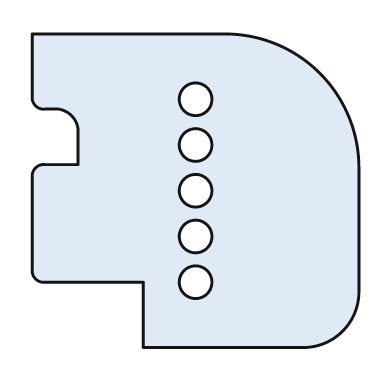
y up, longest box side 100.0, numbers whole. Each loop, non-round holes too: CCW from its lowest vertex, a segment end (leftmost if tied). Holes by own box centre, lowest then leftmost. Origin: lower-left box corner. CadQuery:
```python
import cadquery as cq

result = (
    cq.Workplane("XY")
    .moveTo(34.0, 0.0)
    .lineTo(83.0, 0.0)
    .threePointArc((95.0, 5.0), (100.0, 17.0))
    .lineTo(100.0, 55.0)
    .threePointArc((88.0, 84.0), (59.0, 96.0))
    .lineTo(0.0, 96.0)
    .lineTo(0.0, 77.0)
    .threePointArc((1.0, 74.0), (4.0, 73.0))
    .lineTo(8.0, 73.0)
    .threePointArc((12.0, 71.0), (14.0, 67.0))
    .lineTo(14.0, 56.0)
    .lineTo(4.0, 56.0)
    .threePointArc((1.0, 55.0), (0.0, 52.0))
    .lineTo(0.0, 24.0)
    .threePointArc((1.0, 21.0), (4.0, 20.0))
    .lineTo(34.0, 20.0)
    .close()
    .moveTo(50.0, 20.0)
    .circle(5.0)
    .moveTo(50.0, 34.0)
    .circle(5.0)
    .moveTo(50.0, 48.0)
    .circle(5.0)
    .moveTo(50.0, 62.0)
    .circle(5.0)
    .moveTo(50.0, 76.0)
    .circle(5.0)
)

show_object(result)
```